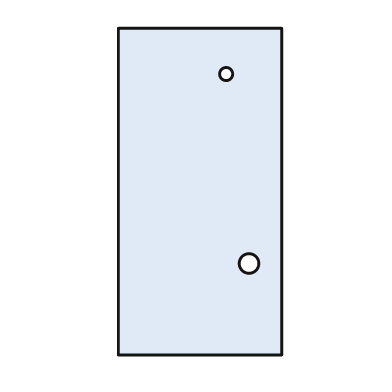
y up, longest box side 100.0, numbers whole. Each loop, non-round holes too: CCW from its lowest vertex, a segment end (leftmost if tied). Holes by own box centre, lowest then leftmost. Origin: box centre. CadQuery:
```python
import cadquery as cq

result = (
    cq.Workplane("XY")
    .moveTo(-25.0, -50.0)
    .lineTo(25.0, -50.0)
    .lineTo(25.0, 50.0)
    .lineTo(-25.0, 50.0)
    .close()
    .moveTo(15.0, -22.0)
    .circle(3.0)
    .moveTo(8.0, 36.0)
    .circle(2.0)
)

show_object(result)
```